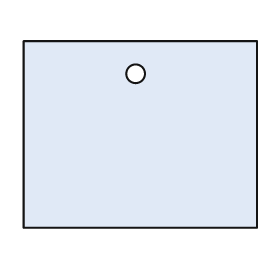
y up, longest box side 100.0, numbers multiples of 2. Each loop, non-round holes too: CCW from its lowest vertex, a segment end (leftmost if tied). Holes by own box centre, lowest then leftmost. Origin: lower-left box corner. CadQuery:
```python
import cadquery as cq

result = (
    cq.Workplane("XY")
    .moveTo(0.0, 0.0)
    .lineTo(100.0, 0.0)
    .lineTo(100.0, 80.0)
    .lineTo(0.0, 80.0)
    .close()
    .moveTo(48.0, 66.0)
    .circle(4.0)
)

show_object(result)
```